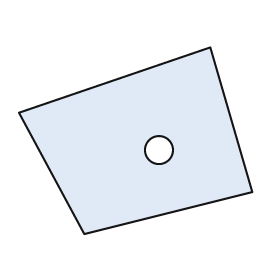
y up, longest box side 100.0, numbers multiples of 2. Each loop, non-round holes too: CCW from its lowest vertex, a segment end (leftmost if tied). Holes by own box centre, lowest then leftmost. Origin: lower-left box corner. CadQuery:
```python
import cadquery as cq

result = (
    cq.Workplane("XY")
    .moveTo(28.0, 0.0)
    .lineTo(100.0, 18.0)
    .lineTo(82.0, 80.0)
    .lineTo(0.0, 52.0)
    .close()
    .moveTo(60.0, 36.0)
    .circle(6.0)
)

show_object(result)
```